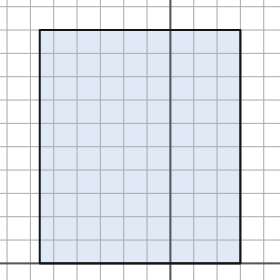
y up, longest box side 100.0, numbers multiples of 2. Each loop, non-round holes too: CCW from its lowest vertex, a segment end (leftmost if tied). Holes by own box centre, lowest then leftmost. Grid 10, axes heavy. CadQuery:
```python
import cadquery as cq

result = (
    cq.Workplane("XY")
    .moveTo(-56.0, 0.0)
    .lineTo(30.0, 0.0)
    .lineTo(30.0, 100.0)
    .lineTo(-56.0, 100.0)
    .close()
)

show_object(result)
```